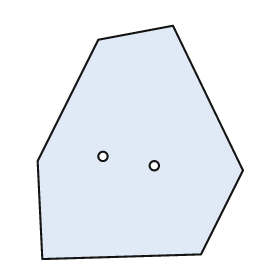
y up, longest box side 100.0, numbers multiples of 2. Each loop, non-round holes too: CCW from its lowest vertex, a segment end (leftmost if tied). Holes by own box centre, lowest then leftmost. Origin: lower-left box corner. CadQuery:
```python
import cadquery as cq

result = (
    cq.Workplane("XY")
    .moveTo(2.0, 0.0)
    .lineTo(70.0, 2.0)
    .lineTo(88.0, 38.0)
    .lineTo(58.0, 100.0)
    .lineTo(26.0, 94.0)
    .lineTo(0.0, 42.0)
    .close()
    .moveTo(50.0, 40.0)
    .circle(2.0)
    .moveTo(28.0, 44.0)
    .circle(2.0)
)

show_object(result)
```